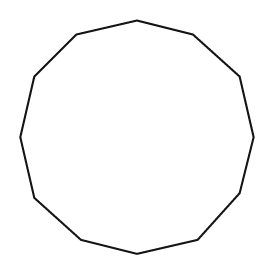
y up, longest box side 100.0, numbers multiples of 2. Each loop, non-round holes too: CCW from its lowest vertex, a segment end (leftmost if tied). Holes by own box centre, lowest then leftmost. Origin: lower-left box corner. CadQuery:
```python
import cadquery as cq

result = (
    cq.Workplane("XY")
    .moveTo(50.0, 0.0)
    .lineTo(76.0, 6.0)
    .lineTo(94.0, 26.0)
    .lineTo(100.0, 50.0)
    .lineTo(94.0, 76.0)
    .lineTo(74.0, 94.0)
    .lineTo(50.0, 100.0)
    .lineTo(24.0, 94.0)
    .lineTo(6.0, 76.0)
    .lineTo(0.0, 50.0)
    .lineTo(6.0, 24.0)
    .lineTo(26.0, 6.0)
    .close()
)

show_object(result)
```